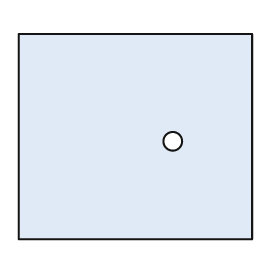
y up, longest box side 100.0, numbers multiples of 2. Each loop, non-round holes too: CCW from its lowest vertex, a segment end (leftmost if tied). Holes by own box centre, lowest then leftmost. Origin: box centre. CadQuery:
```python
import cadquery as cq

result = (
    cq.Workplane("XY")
    .moveTo(-50.0, -44.0)
    .lineTo(50.0, -44.0)
    .lineTo(50.0, 44.0)
    .lineTo(-50.0, 44.0)
    .close()
    .moveTo(16.0, -2.0)
    .circle(4.0)
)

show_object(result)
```